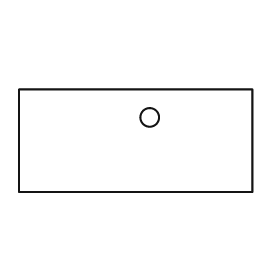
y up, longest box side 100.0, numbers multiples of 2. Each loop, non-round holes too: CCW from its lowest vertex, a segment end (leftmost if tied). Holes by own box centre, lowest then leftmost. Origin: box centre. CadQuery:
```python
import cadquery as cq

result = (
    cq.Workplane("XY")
    .moveTo(-50.0, -22.0)
    .lineTo(50.0, -22.0)
    .lineTo(50.0, 22.0)
    .lineTo(-50.0, 22.0)
    .close()
    .moveTo(6.0, 10.0)
    .circle(4.0)
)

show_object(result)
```